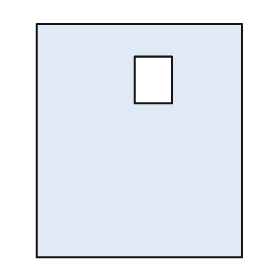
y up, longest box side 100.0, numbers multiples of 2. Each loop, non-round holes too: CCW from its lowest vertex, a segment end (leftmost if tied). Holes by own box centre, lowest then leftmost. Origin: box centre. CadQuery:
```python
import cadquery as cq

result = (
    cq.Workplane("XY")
    .moveTo(-44.0, -50.0)
    .lineTo(44.0, -50.0)
    .lineTo(44.0, 50.0)
    .lineTo(-44.0, 50.0)
    .close()
    .moveTo(-2.0, 16.0)
    .lineTo(14.0, 16.0)
    .lineTo(14.0, 36.0)
    .lineTo(-2.0, 36.0)
    .close()
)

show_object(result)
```